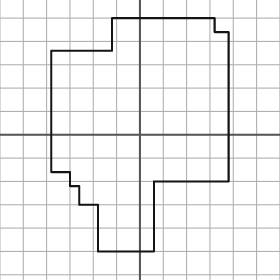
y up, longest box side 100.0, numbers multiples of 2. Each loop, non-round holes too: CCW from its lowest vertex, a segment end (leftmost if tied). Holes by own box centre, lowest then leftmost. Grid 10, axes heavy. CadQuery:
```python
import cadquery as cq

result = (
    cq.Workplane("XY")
    .moveTo(-18.0, -50.0)
    .lineTo(6.0, -50.0)
    .lineTo(6.0, -20.0)
    .lineTo(38.0, -20.0)
    .lineTo(38.0, 44.0)
    .lineTo(32.0, 44.0)
    .lineTo(32.0, 50.0)
    .lineTo(-12.0, 50.0)
    .lineTo(-12.0, 36.0)
    .lineTo(-38.0, 36.0)
    .lineTo(-38.0, -16.0)
    .lineTo(-30.0, -16.0)
    .lineTo(-30.0, -22.0)
    .lineTo(-26.0, -22.0)
    .lineTo(-26.0, -30.0)
    .lineTo(-18.0, -30.0)
    .close()
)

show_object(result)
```